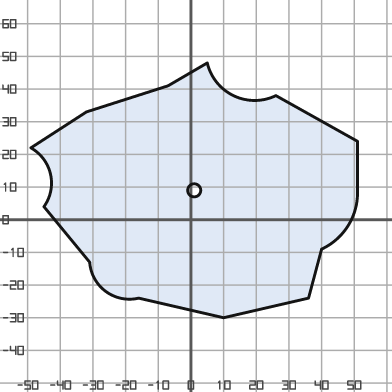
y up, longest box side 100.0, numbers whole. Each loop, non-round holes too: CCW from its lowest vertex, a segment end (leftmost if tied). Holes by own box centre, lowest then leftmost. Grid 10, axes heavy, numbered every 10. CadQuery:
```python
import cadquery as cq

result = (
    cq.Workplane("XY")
    .moveTo(10.0, -30.0)
    .lineTo(36.0, -24.0)
    .lineTo(40.0, -9.0)
    .threePointArc((48.0, -2.0), (51.0, 8.0))
    .lineTo(51.0, 24.0)
    .lineTo(26.0, 38.0)
    .threePointArc((13.0, 38.0), (5.0, 48.0))
    .lineTo(-7.0, 41.0)
    .lineTo(-32.0, 33.0)
    .lineTo(-49.0, 22.0)
    .threePointArc((-43.0, 14.0), (-45.0, 4.0))
    .lineTo(-31.0, -13.0)
    .threePointArc((-26.0, -22.0), (-16.0, -24.0))
    .close()
    .moveTo(1.0, 9.0)
    .circle(2.0)
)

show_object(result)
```